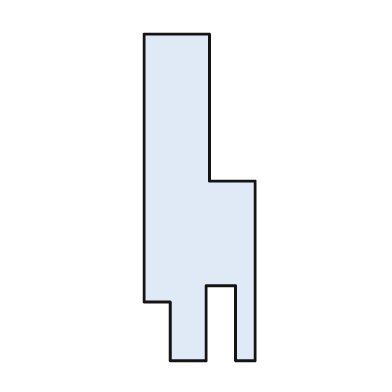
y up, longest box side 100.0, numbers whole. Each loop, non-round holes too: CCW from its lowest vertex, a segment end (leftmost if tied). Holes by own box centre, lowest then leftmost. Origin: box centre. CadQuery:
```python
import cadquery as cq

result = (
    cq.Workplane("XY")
    .moveTo(-9.0, -50.0)
    .lineTo(2.0, -50.0)
    .lineTo(2.0, -27.0)
    .lineTo(11.0, -27.0)
    .lineTo(11.0, -50.0)
    .lineTo(17.0, -50.0)
    .lineTo(17.0, 5.0)
    .lineTo(3.0, 5.0)
    .lineTo(3.0, 50.0)
    .lineTo(-17.0, 50.0)
    .lineTo(-17.0, -32.0)
    .lineTo(-9.0, -32.0)
    .close()
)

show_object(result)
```